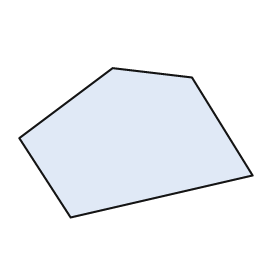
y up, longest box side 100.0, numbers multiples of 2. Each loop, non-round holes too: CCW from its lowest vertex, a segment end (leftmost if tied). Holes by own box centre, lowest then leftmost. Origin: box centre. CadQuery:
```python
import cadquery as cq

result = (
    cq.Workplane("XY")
    .moveTo(-28.0, -32.0)
    .lineTo(50.0, -14.0)
    .lineTo(24.0, 28.0)
    .lineTo(-10.0, 32.0)
    .lineTo(-50.0, 2.0)
    .close()
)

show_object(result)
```